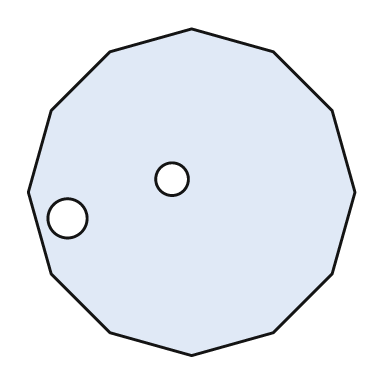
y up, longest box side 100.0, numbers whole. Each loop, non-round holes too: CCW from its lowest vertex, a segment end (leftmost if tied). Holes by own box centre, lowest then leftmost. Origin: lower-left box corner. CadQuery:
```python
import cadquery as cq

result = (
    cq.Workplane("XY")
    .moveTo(50.0, 0.0)
    .lineTo(75.0, 7.0)
    .lineTo(93.0, 25.0)
    .lineTo(100.0, 50.0)
    .lineTo(93.0, 75.0)
    .lineTo(75.0, 93.0)
    .lineTo(50.0, 100.0)
    .lineTo(25.0, 93.0)
    .lineTo(7.0, 75.0)
    .lineTo(0.0, 50.0)
    .lineTo(7.0, 25.0)
    .lineTo(25.0, 7.0)
    .close()
    .moveTo(12.0, 42.0)
    .circle(6.0)
    .moveTo(44.0, 54.0)
    .circle(5.0)
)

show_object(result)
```